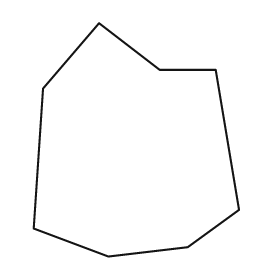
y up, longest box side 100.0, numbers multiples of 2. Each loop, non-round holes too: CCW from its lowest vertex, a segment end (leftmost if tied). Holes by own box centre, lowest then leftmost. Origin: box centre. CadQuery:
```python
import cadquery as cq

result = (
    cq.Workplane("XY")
    .moveTo(-12.0, -50.0)
    .lineTo(22.0, -46.0)
    .lineTo(44.0, -30.0)
    .lineTo(34.0, 30.0)
    .lineTo(10.0, 30.0)
    .lineTo(-16.0, 50.0)
    .lineTo(-40.0, 22.0)
    .lineTo(-44.0, -38.0)
    .close()
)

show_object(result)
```